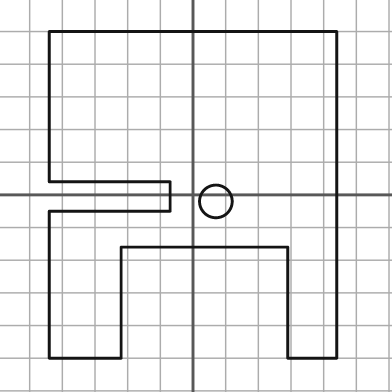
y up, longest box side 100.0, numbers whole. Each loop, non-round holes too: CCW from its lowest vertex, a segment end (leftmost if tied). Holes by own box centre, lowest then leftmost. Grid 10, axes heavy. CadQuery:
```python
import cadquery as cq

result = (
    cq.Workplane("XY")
    .moveTo(-44.0, -50.0)
    .lineTo(-22.0, -50.0)
    .lineTo(-22.0, -16.0)
    .lineTo(29.0, -16.0)
    .lineTo(29.0, -50.0)
    .lineTo(44.0, -50.0)
    .lineTo(44.0, 50.0)
    .lineTo(-44.0, 50.0)
    .lineTo(-44.0, 4.0)
    .lineTo(-7.0, 4.0)
    .lineTo(-7.0, -5.0)
    .lineTo(-44.0, -5.0)
    .close()
    .moveTo(7.0, -2.0)
    .circle(5.0)
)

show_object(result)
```